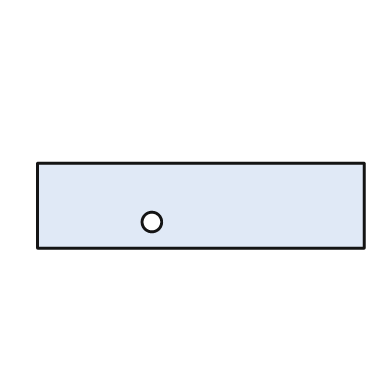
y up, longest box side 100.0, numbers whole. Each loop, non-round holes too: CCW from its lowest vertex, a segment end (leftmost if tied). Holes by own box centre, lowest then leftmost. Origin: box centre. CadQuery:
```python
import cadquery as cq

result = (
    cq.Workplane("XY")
    .moveTo(-50.0, -13.0)
    .lineTo(50.0, -13.0)
    .lineTo(50.0, 13.0)
    .lineTo(-50.0, 13.0)
    .close()
    .moveTo(-15.0, -5.0)
    .circle(3.0)
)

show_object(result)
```